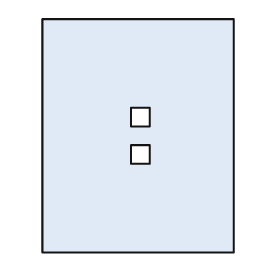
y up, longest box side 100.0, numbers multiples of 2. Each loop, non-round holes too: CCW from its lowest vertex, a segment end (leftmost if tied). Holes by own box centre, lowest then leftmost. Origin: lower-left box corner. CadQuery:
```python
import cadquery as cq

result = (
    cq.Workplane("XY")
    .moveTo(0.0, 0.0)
    .lineTo(82.0, 0.0)
    .lineTo(82.0, 100.0)
    .lineTo(0.0, 100.0)
    .close()
    .moveTo(38.0, 38.0)
    .lineTo(46.0, 38.0)
    .lineTo(46.0, 46.0)
    .lineTo(38.0, 46.0)
    .close()
    .moveTo(38.0, 54.0)
    .lineTo(46.0, 54.0)
    .lineTo(46.0, 62.0)
    .lineTo(38.0, 62.0)
    .close()
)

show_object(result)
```